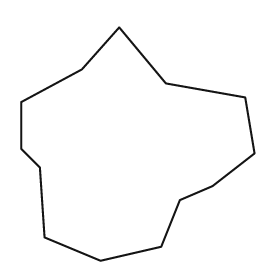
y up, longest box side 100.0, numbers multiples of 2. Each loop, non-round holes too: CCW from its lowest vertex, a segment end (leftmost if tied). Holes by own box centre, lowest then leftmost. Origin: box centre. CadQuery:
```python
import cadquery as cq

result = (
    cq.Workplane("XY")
    .moveTo(-16.0, -50.0)
    .lineTo(10.0, -44.0)
    .lineTo(18.0, -24.0)
    .lineTo(32.0, -18.0)
    .lineTo(50.0, -4.0)
    .lineTo(46.0, 20.0)
    .lineTo(12.0, 26.0)
    .lineTo(-8.0, 50.0)
    .lineTo(-24.0, 32.0)
    .lineTo(-50.0, 18.0)
    .lineTo(-50.0, -2.0)
    .lineTo(-42.0, -10.0)
    .lineTo(-40.0, -40.0)
    .close()
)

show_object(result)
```